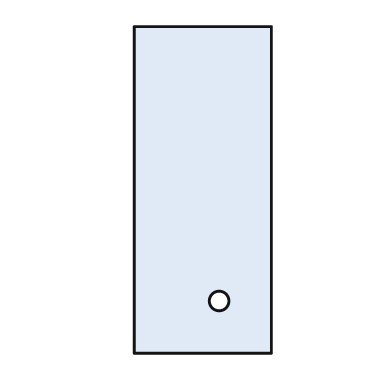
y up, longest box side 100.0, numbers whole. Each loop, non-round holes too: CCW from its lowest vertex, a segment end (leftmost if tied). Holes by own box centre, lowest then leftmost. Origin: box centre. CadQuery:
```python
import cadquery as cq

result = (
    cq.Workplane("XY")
    .moveTo(-21.0, -50.0)
    .lineTo(21.0, -50.0)
    .lineTo(21.0, 50.0)
    .lineTo(-21.0, 50.0)
    .close()
    .moveTo(5.0, -34.0)
    .circle(3.0)
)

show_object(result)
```